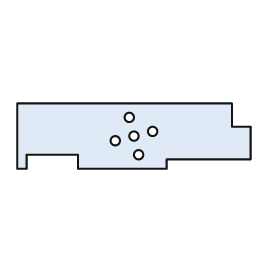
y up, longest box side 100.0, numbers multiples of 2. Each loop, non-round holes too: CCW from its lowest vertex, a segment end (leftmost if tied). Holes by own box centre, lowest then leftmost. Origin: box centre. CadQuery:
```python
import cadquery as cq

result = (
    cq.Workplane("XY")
    .moveTo(-50.0, -14.0)
    .lineTo(-46.0, -14.0)
    .lineTo(-46.0, -8.0)
    .lineTo(-24.0, -8.0)
    .lineTo(-24.0, -14.0)
    .lineTo(14.0, -14.0)
    .lineTo(14.0, -10.0)
    .lineTo(50.0, -10.0)
    .lineTo(50.0, 4.0)
    .lineTo(42.0, 4.0)
    .lineTo(42.0, 14.0)
    .lineTo(-50.0, 14.0)
    .close()
    .moveTo(2.0, -8.0)
    .circle(2.0)
    .moveTo(-8.0, -2.0)
    .circle(2.0)
    .moveTo(0.0, 0.0)
    .circle(2.0)
    .moveTo(8.0, 2.0)
    .circle(2.0)
    .moveTo(-2.0, 8.0)
    .circle(2.0)
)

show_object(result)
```